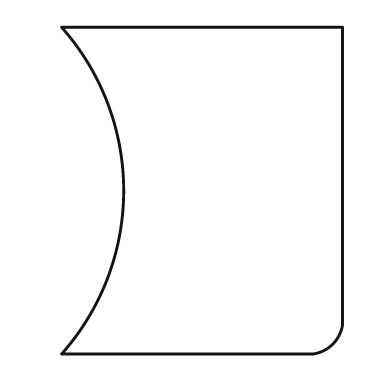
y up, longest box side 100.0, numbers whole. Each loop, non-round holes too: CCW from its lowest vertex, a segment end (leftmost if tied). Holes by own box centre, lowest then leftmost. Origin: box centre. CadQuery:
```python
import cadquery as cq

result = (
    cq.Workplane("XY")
    .moveTo(-43.0, -50.0)
    .lineTo(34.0, -50.0)
    .threePointArc((40.0, -47.0), (43.0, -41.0))
    .lineTo(43.0, 50.0)
    .lineTo(-43.0, 50.0)
    .threePointArc((-24.0, 0.0), (-43.0, -50.0))
    .close()
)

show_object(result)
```